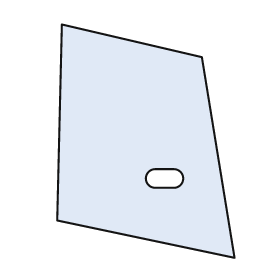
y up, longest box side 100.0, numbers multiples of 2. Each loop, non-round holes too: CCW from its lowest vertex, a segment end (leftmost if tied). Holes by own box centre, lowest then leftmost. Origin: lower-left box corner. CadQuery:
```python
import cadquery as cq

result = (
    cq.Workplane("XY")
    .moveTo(76.0, 0.0)
    .lineTo(62.0, 86.0)
    .lineTo(2.0, 100.0)
    .lineTo(0.0, 16.0)
    .close()
    .moveTo(42.0, 30.0)
    .lineTo(50.0, 30.0)
    .threePointArc((54.0, 34.0), (50.0, 38.0))
    .lineTo(42.0, 38.0)
    .threePointArc((38.0, 34.0), (42.0, 30.0))
    .close()
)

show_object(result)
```